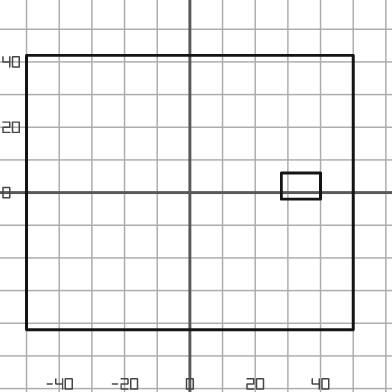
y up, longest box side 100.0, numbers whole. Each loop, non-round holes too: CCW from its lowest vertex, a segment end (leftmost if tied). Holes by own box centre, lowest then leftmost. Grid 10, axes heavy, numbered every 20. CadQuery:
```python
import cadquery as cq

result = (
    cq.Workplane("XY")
    .moveTo(-50.0, -42.0)
    .lineTo(50.0, -42.0)
    .lineTo(50.0, 42.0)
    .lineTo(-50.0, 42.0)
    .close()
    .moveTo(28.0, -2.0)
    .lineTo(40.0, -2.0)
    .lineTo(40.0, 6.0)
    .lineTo(28.0, 6.0)
    .close()
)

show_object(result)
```